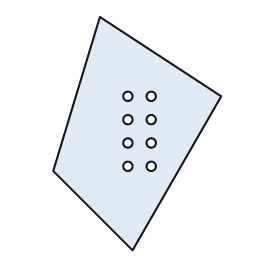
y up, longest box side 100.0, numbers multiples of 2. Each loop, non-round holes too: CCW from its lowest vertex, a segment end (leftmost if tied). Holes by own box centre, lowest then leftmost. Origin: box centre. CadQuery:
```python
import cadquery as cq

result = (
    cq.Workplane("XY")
    .moveTo(-2.0, -50.0)
    .lineTo(36.0, 16.0)
    .lineTo(-16.0, 50.0)
    .lineTo(-36.0, -16.0)
    .close()
    .moveTo(-4.0, -14.0)
    .circle(2.0)
    .moveTo(6.0, -14.0)
    .circle(2.0)
    .moveTo(-4.0, -4.0)
    .circle(2.0)
    .moveTo(6.0, -4.0)
    .circle(2.0)
    .moveTo(-4.0, 6.0)
    .circle(2.0)
    .moveTo(6.0, 6.0)
    .circle(2.0)
    .moveTo(-4.0, 16.0)
    .circle(2.0)
    .moveTo(6.0, 16.0)
    .circle(2.0)
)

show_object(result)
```